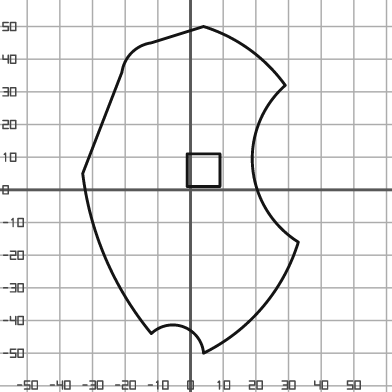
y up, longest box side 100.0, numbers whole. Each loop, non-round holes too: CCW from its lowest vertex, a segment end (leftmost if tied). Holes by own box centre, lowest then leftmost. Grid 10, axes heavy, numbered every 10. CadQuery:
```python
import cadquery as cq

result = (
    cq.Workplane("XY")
    .moveTo(4.0, -50.0)
    .threePointArc((22.0, -36.0), (33.0, -16.0))
    .threePointArc((19.0, 7.0), (29.0, 32.0))
    .threePointArc((18.0, 43.0), (4.0, 50.0))
    .lineTo(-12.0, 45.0)
    .threePointArc((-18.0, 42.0), (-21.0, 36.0))
    .lineTo(-33.0, 5.0)
    .threePointArc((-26.0, -21.0), (-12.0, -44.0))
    .threePointArc((-2.0, -42.0), (4.0, -50.0))
    .close()
    .moveTo(-1.0, 1.0)
    .lineTo(9.0, 1.0)
    .lineTo(9.0, 11.0)
    .lineTo(-1.0, 11.0)
    .close()
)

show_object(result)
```